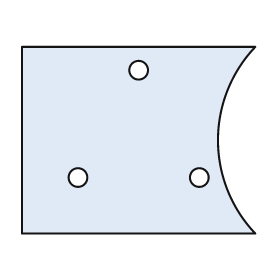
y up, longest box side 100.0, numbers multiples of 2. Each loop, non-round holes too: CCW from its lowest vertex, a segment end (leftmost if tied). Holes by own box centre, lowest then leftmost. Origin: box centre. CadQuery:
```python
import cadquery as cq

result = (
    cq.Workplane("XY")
    .moveTo(-50.0, -40.0)
    .lineTo(50.0, -40.0)
    .threePointArc((34.0, 0.0), (50.0, 40.0))
    .lineTo(-50.0, 40.0)
    .close()
    .moveTo(-26.0, -16.0)
    .circle(4.0)
    .moveTo(26.0, -16.0)
    .circle(4.0)
    .moveTo(0.0, 30.0)
    .circle(4.0)
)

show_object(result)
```